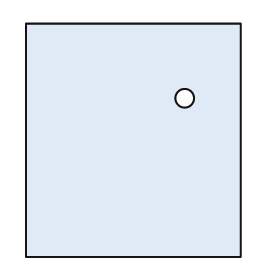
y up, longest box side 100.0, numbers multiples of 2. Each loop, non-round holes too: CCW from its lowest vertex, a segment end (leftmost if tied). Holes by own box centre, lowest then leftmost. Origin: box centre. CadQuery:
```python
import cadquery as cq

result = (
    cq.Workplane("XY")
    .moveTo(-46.0, -50.0)
    .lineTo(46.0, -50.0)
    .lineTo(46.0, 50.0)
    .lineTo(-46.0, 50.0)
    .close()
    .moveTo(22.0, 18.0)
    .circle(4.0)
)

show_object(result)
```